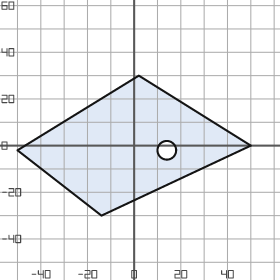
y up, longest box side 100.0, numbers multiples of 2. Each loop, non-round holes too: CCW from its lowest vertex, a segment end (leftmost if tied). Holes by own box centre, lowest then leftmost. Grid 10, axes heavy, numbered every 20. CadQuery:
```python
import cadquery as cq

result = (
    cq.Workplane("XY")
    .moveTo(-14.0, -30.0)
    .lineTo(50.0, 0.0)
    .lineTo(2.0, 30.0)
    .lineTo(-50.0, -2.0)
    .close()
    .moveTo(14.0, -2.0)
    .circle(4.0)
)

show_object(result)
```